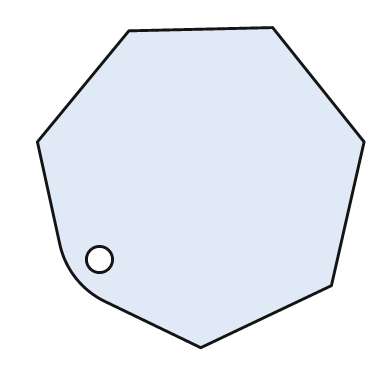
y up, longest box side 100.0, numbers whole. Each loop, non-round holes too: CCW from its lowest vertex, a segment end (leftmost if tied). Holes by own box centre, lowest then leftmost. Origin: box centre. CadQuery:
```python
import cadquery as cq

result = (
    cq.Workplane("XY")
    .moveTo(0.0, -49.0)
    .lineTo(40.0, -30.0)
    .lineTo(50.0, 14.0)
    .lineTo(22.0, 49.0)
    .lineTo(-22.0, 48.0)
    .lineTo(-50.0, 14.0)
    .lineTo(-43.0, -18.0)
    .threePointArc((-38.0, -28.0), (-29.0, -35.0))
    .close()
    .moveTo(-31.0, -22.0)
    .circle(4.0)
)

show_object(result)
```